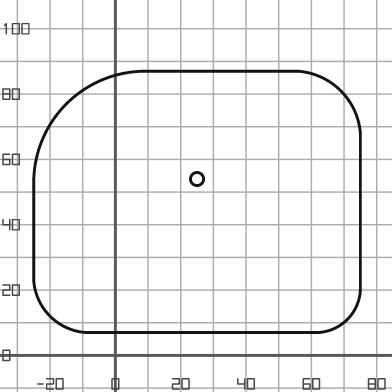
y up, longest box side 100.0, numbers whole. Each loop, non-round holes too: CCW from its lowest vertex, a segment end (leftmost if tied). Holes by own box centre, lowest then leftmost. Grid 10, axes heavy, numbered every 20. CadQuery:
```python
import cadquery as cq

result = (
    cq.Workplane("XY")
    .moveTo(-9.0, 7.0)
    .lineTo(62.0, 7.0)
    .threePointArc((71.0, 11.0), (75.0, 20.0))
    .lineTo(75.0, 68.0)
    .threePointArc((69.0, 81.0), (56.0, 87.0))
    .lineTo(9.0, 87.0)
    .threePointArc((-15.0, 77.0), (-25.0, 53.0))
    .lineTo(-25.0, 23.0)
    .threePointArc((-20.0, 12.0), (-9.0, 7.0))
    .close()
    .moveTo(25.0, 54.0)
    .circle(2.0)
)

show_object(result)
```